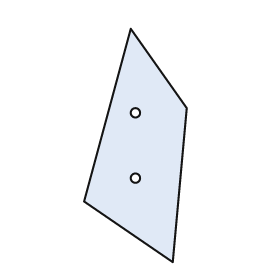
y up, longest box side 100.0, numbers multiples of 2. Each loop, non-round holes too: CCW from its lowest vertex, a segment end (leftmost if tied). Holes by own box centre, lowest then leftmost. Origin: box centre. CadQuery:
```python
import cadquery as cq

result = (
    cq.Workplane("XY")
    .moveTo(16.0, -50.0)
    .lineTo(22.0, 16.0)
    .lineTo(-2.0, 50.0)
    .lineTo(-22.0, -24.0)
    .close()
    .moveTo(0.0, -14.0)
    .circle(2.0)
    .moveTo(0.0, 14.0)
    .circle(2.0)
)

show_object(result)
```